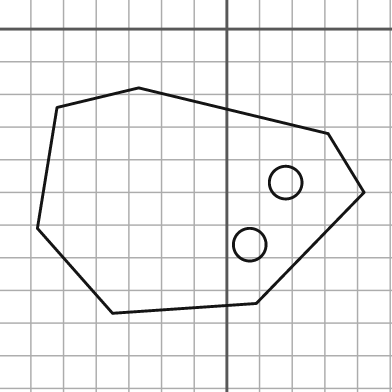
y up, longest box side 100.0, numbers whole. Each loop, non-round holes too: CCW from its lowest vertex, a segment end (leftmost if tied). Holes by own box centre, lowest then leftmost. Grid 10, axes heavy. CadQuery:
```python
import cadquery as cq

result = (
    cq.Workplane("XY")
    .moveTo(-35.0, -87.0)
    .lineTo(9.0, -84.0)
    .lineTo(42.0, -50.0)
    .lineTo(31.0, -32.0)
    .lineTo(-27.0, -18.0)
    .lineTo(-52.0, -24.0)
    .lineTo(-58.0, -61.0)
    .close()
    .moveTo(7.0, -66.0)
    .circle(5.0)
    .moveTo(18.0, -47.0)
    .circle(5.0)
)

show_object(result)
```